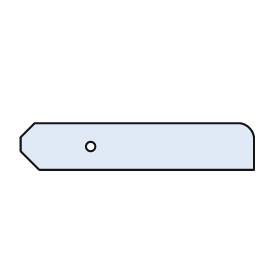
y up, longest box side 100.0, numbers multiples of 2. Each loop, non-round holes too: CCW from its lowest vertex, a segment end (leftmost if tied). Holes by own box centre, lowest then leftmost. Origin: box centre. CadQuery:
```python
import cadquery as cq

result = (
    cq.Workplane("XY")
    .moveTo(-42.0, -10.0)
    .lineTo(50.0, -10.0)
    .lineTo(50.0, 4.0)
    .threePointArc((48.0, 8.0), (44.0, 10.0))
    .lineTo(-44.0, 10.0)
    .lineTo(-50.0, 4.0)
    .lineTo(-50.0, -2.0)
    .close()
    .moveTo(-20.0, 0.0)
    .circle(2.0)
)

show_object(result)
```